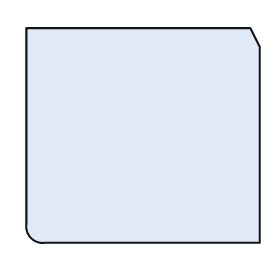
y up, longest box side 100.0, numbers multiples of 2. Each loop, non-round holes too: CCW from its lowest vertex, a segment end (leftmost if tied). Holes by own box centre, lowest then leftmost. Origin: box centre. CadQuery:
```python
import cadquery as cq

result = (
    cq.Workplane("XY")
    .moveTo(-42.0, -46.0)
    .lineTo(50.0, -46.0)
    .lineTo(50.0, 38.0)
    .lineTo(46.0, 46.0)
    .lineTo(-50.0, 46.0)
    .lineTo(-50.0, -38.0)
    .threePointArc((-48.0, -44.0), (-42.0, -46.0))
    .close()
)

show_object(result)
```